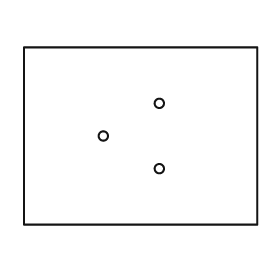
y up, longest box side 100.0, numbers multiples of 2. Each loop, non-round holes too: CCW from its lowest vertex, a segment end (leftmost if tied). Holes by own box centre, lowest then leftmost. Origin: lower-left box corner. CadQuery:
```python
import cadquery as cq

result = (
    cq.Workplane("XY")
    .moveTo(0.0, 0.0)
    .lineTo(100.0, 0.0)
    .lineTo(100.0, 76.0)
    .lineTo(0.0, 76.0)
    .close()
    .moveTo(58.0, 24.0)
    .circle(2.0)
    .moveTo(34.0, 38.0)
    .circle(2.0)
    .moveTo(58.0, 52.0)
    .circle(2.0)
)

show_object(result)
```